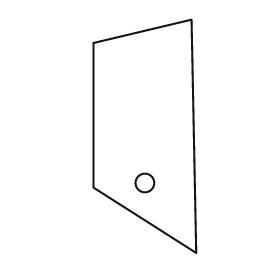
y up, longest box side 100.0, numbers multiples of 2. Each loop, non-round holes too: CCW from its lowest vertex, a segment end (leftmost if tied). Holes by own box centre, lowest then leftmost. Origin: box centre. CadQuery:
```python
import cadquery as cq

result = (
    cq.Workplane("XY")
    .moveTo(22.0, -50.0)
    .lineTo(20.0, 50.0)
    .lineTo(-22.0, 40.0)
    .lineTo(-22.0, -22.0)
    .close()
    .moveTo(0.0, -20.0)
    .circle(4.0)
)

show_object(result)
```